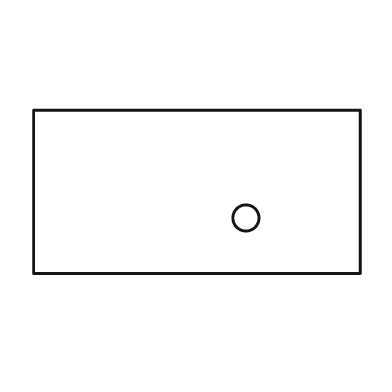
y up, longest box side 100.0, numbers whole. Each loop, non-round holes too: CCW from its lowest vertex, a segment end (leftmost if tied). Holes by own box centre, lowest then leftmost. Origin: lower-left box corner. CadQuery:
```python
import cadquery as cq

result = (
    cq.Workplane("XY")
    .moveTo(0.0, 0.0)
    .lineTo(100.0, 0.0)
    .lineTo(100.0, 50.0)
    .lineTo(0.0, 50.0)
    .close()
    .moveTo(65.0, 17.0)
    .circle(4.0)
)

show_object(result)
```